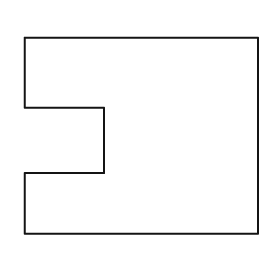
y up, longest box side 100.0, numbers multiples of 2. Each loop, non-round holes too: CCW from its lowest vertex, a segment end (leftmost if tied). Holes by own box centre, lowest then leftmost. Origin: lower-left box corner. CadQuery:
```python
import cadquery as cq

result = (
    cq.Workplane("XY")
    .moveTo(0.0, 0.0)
    .lineTo(100.0, 0.0)
    .lineTo(100.0, 84.0)
    .lineTo(0.0, 84.0)
    .lineTo(0.0, 54.0)
    .lineTo(34.0, 54.0)
    .lineTo(34.0, 26.0)
    .lineTo(0.0, 26.0)
    .close()
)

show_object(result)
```